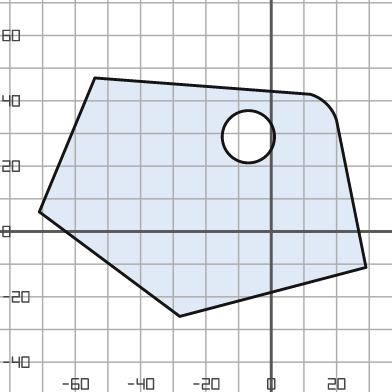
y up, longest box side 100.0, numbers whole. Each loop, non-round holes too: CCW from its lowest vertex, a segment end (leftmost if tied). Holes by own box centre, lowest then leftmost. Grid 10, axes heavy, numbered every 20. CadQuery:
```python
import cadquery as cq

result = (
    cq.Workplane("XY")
    .moveTo(-28.0, -26.0)
    .lineTo(29.0, -11.0)
    .lineTo(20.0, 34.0)
    .threePointArc((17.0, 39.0), (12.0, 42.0))
    .lineTo(-54.0, 47.0)
    .lineTo(-71.0, 6.0)
    .close()
    .moveTo(-7.0, 29.0)
    .circle(8.0)
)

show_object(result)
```